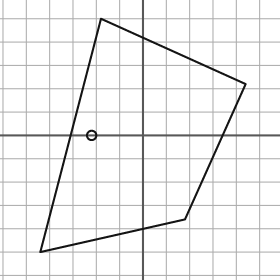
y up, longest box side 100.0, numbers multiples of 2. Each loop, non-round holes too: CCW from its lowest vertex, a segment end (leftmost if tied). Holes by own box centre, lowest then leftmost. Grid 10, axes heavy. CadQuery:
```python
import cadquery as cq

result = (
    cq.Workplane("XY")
    .moveTo(-44.0, -50.0)
    .lineTo(18.0, -36.0)
    .lineTo(44.0, 22.0)
    .lineTo(-18.0, 50.0)
    .close()
    .moveTo(-22.0, 0.0)
    .circle(2.0)
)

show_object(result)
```